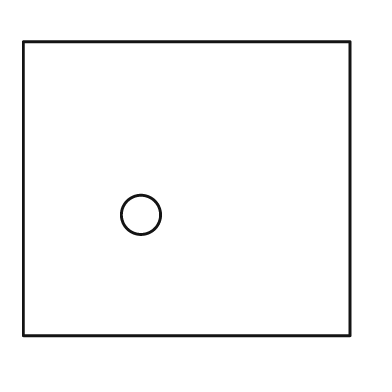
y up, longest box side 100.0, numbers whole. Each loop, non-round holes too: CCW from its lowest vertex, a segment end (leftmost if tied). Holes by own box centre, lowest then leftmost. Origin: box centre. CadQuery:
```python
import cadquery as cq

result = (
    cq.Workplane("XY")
    .moveTo(-50.0, -45.0)
    .lineTo(50.0, -45.0)
    .lineTo(50.0, 45.0)
    .lineTo(-50.0, 45.0)
    .close()
    .moveTo(-14.0, -8.0)
    .circle(6.0)
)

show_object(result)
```